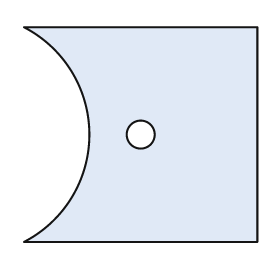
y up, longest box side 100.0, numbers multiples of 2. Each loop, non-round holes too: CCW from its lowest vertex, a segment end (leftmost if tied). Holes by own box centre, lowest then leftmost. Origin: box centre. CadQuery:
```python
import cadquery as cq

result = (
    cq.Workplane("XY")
    .moveTo(-50.0, -46.0)
    .lineTo(50.0, -46.0)
    .lineTo(50.0, 46.0)
    .lineTo(-50.0, 46.0)
    .threePointArc((-22.0, 0.0), (-50.0, -46.0))
    .close()
    .moveTo(0.0, 0.0)
    .circle(6.0)
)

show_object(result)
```